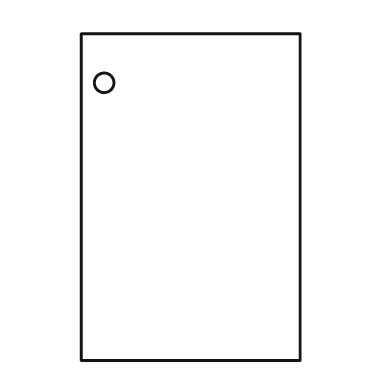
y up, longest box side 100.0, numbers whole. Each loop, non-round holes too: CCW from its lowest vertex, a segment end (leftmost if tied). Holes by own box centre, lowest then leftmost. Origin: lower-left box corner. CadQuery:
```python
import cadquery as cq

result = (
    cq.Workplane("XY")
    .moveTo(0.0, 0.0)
    .lineTo(67.0, 0.0)
    .lineTo(67.0, 100.0)
    .lineTo(0.0, 100.0)
    .close()
    .moveTo(7.0, 85.0)
    .circle(3.0)
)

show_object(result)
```